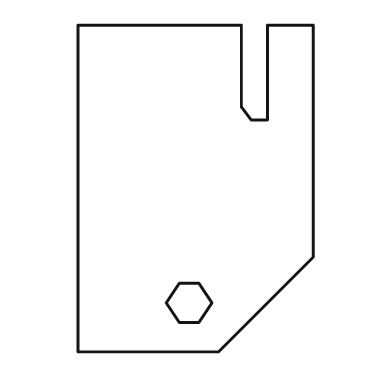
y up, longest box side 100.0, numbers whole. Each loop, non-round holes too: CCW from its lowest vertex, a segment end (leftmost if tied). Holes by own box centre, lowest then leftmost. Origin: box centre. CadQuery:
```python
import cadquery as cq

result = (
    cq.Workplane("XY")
    .moveTo(-36.0, -50.0)
    .lineTo(7.0, -50.0)
    .lineTo(36.0, -21.0)
    .lineTo(36.0, 50.0)
    .lineTo(22.0, 50.0)
    .lineTo(22.0, 21.0)
    .lineTo(17.0, 21.0)
    .lineTo(14.0, 25.0)
    .lineTo(14.0, 50.0)
    .lineTo(-36.0, 50.0)
    .close()
    .moveTo(-5.0, -41.0)
    .lineTo(1.0, -41.0)
    .lineTo(5.0, -35.0)
    .lineTo(1.0, -29.0)
    .lineTo(-5.0, -29.0)
    .lineTo(-9.0, -35.0)
    .close()
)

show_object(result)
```